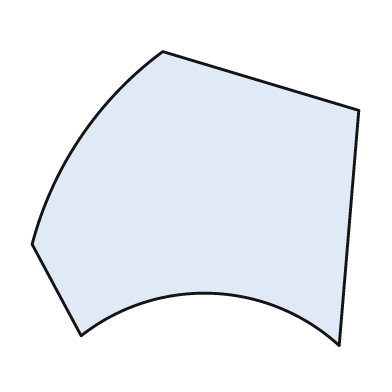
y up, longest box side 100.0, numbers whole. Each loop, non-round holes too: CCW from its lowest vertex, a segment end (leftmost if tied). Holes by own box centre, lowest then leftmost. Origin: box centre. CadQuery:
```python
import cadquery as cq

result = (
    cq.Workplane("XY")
    .moveTo(44.0, -45.0)
    .lineTo(50.0, 27.0)
    .lineTo(-10.0, 45.0)
    .threePointArc((-35.0, 19.0), (-50.0, -14.0))
    .lineTo(-35.0, -42.0)
    .threePointArc((5.0, -29.0), (44.0, -45.0))
    .close()
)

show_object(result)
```